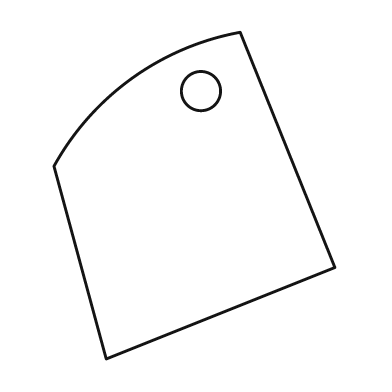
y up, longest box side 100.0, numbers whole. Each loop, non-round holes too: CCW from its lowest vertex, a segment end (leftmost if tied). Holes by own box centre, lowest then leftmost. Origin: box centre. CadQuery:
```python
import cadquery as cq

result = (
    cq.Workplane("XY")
    .moveTo(-27.0, -50.0)
    .lineTo(43.0, -22.0)
    .lineTo(14.0, 50.0)
    .threePointArc((-19.0, 36.0), (-43.0, 9.0))
    .close()
    .moveTo(2.0, 32.0)
    .circle(6.0)
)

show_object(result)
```